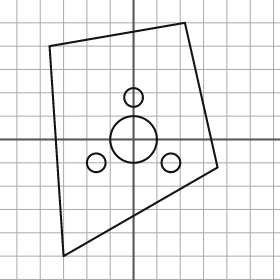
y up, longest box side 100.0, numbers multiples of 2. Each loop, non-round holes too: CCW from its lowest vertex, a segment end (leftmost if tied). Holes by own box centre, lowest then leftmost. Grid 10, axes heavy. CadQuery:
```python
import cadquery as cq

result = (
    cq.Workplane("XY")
    .moveTo(-30.0, -50.0)
    .lineTo(36.0, -12.0)
    .lineTo(22.0, 50.0)
    .lineTo(-36.0, 40.0)
    .close()
    .moveTo(-16.0, -10.0)
    .circle(4.0)
    .moveTo(16.0, -10.0)
    .circle(4.0)
    .moveTo(0.0, 0.0)
    .circle(10.0)
    .moveTo(0.0, 18.0)
    .circle(4.0)
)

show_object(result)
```